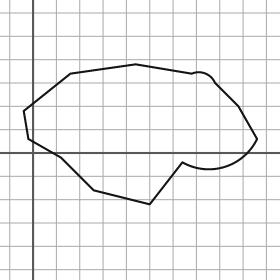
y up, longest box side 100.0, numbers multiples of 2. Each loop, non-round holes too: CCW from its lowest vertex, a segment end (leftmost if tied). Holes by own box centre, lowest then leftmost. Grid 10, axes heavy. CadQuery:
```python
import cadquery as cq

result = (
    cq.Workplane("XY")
    .moveTo(50.0, -22.0)
    .lineTo(64.0, -4.0)
    .threePointArc((82.0, -6.0), (96.0, 6.0))
    .lineTo(88.0, 20.0)
    .lineTo(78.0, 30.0)
    .threePointArc((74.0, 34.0), (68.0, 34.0))
    .lineTo(44.0, 38.0)
    .lineTo(16.0, 34.0)
    .lineTo(-4.0, 18.0)
    .lineTo(-2.0, 6.0)
    .lineTo(12.0, -2.0)
    .lineTo(26.0, -16.0)
    .close()
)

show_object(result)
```